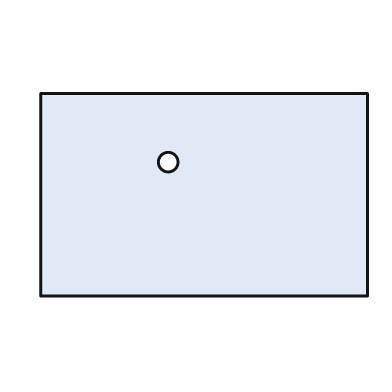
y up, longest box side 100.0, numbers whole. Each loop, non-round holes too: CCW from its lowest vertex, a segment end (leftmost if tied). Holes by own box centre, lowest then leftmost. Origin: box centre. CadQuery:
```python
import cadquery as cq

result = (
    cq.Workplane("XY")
    .moveTo(-50.0, -31.0)
    .lineTo(50.0, -31.0)
    .lineTo(50.0, 31.0)
    .lineTo(-50.0, 31.0)
    .close()
    .moveTo(-11.0, 10.0)
    .circle(3.0)
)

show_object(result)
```